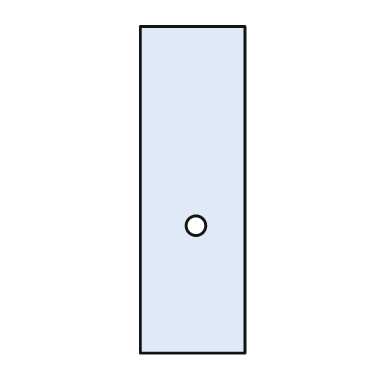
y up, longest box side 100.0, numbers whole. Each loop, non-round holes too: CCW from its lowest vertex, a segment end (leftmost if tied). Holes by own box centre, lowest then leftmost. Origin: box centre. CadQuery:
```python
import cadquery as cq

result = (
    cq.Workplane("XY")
    .moveTo(-16.0, -50.0)
    .lineTo(16.0, -50.0)
    .lineTo(16.0, 50.0)
    .lineTo(-16.0, 50.0)
    .close()
    .moveTo(1.0, -11.0)
    .circle(3.0)
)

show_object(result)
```